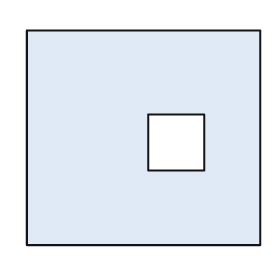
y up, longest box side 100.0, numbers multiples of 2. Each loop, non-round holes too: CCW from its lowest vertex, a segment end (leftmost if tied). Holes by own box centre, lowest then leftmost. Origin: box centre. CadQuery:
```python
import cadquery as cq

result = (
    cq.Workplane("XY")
    .moveTo(-50.0, -46.0)
    .lineTo(50.0, -46.0)
    .lineTo(50.0, 46.0)
    .lineTo(-50.0, 46.0)
    .close()
    .moveTo(2.0, -14.0)
    .lineTo(26.0, -14.0)
    .lineTo(26.0, 10.0)
    .lineTo(2.0, 10.0)
    .close()
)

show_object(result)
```